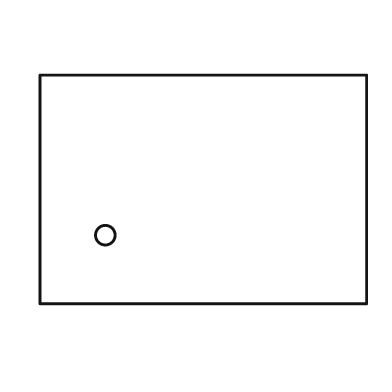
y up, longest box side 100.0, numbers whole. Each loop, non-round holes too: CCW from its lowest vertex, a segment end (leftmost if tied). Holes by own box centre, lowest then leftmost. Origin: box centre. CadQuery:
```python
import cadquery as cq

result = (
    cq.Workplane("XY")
    .moveTo(-50.0, -35.0)
    .lineTo(50.0, -35.0)
    .lineTo(50.0, 35.0)
    .lineTo(-50.0, 35.0)
    .close()
    .moveTo(-30.0, -14.0)
    .circle(3.0)
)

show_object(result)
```